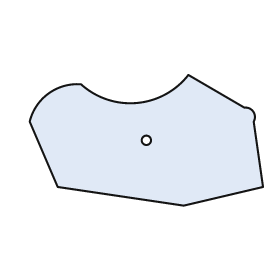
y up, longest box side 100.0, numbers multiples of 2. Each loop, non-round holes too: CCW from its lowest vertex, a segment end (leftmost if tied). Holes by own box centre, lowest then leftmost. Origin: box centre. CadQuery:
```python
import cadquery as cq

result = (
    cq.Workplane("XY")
    .moveTo(16.0, -28.0)
    .lineTo(50.0, -20.0)
    .lineTo(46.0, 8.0)
    .threePointArc((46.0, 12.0), (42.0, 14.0))
    .lineTo(18.0, 28.0)
    .threePointArc((-4.0, 16.0), (-28.0, 24.0))
    .threePointArc((-42.0, 20.0), (-50.0, 8.0))
    .lineTo(-38.0, -20.0)
    .close()
    .moveTo(0.0, 0.0)
    .circle(2.0)
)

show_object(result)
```